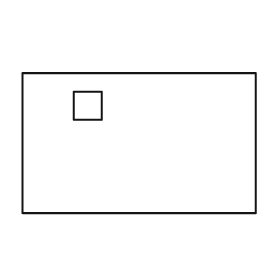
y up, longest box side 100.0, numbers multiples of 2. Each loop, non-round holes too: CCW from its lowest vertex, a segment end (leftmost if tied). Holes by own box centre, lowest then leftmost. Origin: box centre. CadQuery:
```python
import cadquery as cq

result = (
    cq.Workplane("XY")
    .moveTo(-50.0, -30.0)
    .lineTo(50.0, -30.0)
    .lineTo(50.0, 30.0)
    .lineTo(-50.0, 30.0)
    .close()
    .moveTo(-28.0, 10.0)
    .lineTo(-16.0, 10.0)
    .lineTo(-16.0, 22.0)
    .lineTo(-28.0, 22.0)
    .close()
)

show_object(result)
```